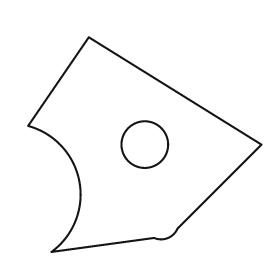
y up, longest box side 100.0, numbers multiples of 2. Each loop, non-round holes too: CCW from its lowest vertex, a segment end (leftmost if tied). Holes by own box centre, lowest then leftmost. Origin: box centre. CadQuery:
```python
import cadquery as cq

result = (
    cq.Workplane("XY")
    .moveTo(-40.0, -46.0)
    .lineTo(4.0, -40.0)
    .threePointArc((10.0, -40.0), (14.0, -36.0))
    .lineTo(50.0, 0.0)
    .lineTo(-24.0, 46.0)
    .lineTo(-50.0, 8.0)
    .threePointArc((-28.0, -16.0), (-40.0, -46.0))
    .close()
    .moveTo(0.0, 0.0)
    .circle(10.0)
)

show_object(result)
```